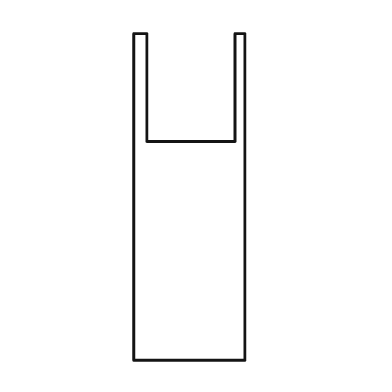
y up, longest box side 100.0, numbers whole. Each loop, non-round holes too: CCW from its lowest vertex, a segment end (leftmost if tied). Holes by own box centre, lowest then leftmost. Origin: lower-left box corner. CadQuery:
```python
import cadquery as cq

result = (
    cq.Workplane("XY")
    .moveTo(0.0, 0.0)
    .lineTo(34.0, 0.0)
    .lineTo(34.0, 100.0)
    .lineTo(31.0, 100.0)
    .lineTo(31.0, 67.0)
    .lineTo(4.0, 67.0)
    .lineTo(4.0, 100.0)
    .lineTo(0.0, 100.0)
    .close()
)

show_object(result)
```